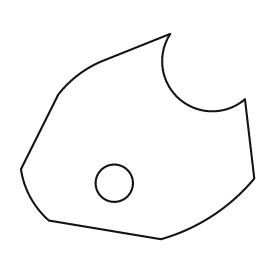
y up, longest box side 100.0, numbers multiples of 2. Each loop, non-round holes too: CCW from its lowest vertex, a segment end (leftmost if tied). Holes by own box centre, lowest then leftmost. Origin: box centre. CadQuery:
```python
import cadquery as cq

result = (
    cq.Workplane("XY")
    .moveTo(10.0, -44.0)
    .threePointArc((32.0, -34.0), (50.0, -18.0))
    .lineTo(46.0, 16.0)
    .threePointArc((18.0, 16.0), (14.0, 44.0))
    .lineTo(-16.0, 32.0)
    .threePointArc((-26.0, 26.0), (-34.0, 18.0))
    .lineTo(-50.0, -14.0)
    .threePointArc((-46.0, -26.0), (-38.0, -36.0))
    .close()
    .moveTo(-10.0, -20.0)
    .circle(8.0)
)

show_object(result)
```